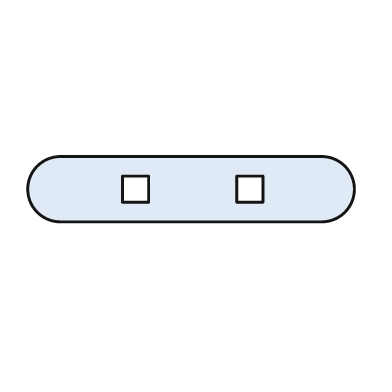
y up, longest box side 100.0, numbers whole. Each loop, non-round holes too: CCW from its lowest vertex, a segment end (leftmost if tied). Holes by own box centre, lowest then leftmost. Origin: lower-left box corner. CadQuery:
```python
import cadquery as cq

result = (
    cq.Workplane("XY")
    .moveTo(10.0, 0.0)
    .lineTo(90.0, 0.0)
    .threePointArc((100.0, 10.0), (90.0, 20.0))
    .lineTo(10.0, 20.0)
    .threePointArc((0.0, 10.0), (10.0, 0.0))
    .close()
    .moveTo(29.0, 6.0)
    .lineTo(37.0, 6.0)
    .lineTo(37.0, 14.0)
    .lineTo(29.0, 14.0)
    .close()
    .moveTo(64.0, 6.0)
    .lineTo(72.0, 6.0)
    .lineTo(72.0, 14.0)
    .lineTo(64.0, 14.0)
    .close()
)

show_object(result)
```